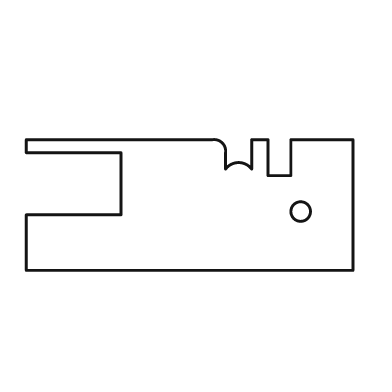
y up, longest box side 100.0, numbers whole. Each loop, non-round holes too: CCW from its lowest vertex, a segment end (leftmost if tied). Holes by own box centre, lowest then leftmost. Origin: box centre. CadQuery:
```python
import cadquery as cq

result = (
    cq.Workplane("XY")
    .moveTo(-50.0, -20.0)
    .lineTo(50.0, -20.0)
    .lineTo(50.0, 20.0)
    .lineTo(31.0, 20.0)
    .lineTo(31.0, 9.0)
    .lineTo(24.0, 9.0)
    .lineTo(24.0, 20.0)
    .lineTo(19.0, 20.0)
    .lineTo(19.0, 11.0)
    .threePointArc((15.0, 13.0), (11.0, 11.0))
    .lineTo(11.0, 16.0)
    .threePointArc((10.0, 19.0), (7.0, 20.0))
    .lineTo(-50.0, 20.0)
    .lineTo(-50.0, 16.0)
    .lineTo(-21.0, 16.0)
    .lineTo(-21.0, -3.0)
    .lineTo(-50.0, -3.0)
    .close()
    .moveTo(34.0, -2.0)
    .circle(3.0)
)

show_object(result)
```